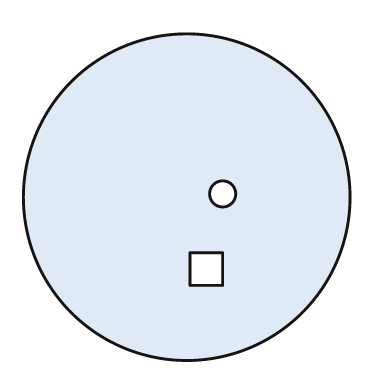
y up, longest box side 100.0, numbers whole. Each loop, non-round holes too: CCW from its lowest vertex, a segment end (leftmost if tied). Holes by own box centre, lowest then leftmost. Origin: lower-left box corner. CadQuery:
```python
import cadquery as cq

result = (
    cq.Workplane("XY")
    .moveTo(50.0, 50.0)
    .circle(50.0)
    .moveTo(51.0, 23.0)
    .lineTo(61.0, 23.0)
    .lineTo(61.0, 33.0)
    .lineTo(51.0, 33.0)
    .close()
    .moveTo(61.0, 51.0)
    .circle(4.0)
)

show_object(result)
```